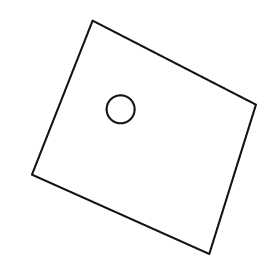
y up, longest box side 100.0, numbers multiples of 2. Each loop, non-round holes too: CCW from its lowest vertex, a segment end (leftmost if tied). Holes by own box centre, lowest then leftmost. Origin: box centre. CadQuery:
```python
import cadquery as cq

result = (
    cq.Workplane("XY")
    .moveTo(28.0, -50.0)
    .lineTo(48.0, 14.0)
    .lineTo(-22.0, 50.0)
    .lineTo(-48.0, -16.0)
    .close()
    .moveTo(-10.0, 12.0)
    .circle(6.0)
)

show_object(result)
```